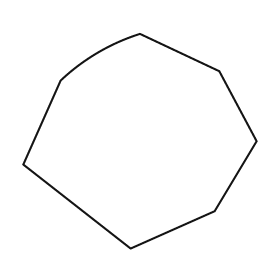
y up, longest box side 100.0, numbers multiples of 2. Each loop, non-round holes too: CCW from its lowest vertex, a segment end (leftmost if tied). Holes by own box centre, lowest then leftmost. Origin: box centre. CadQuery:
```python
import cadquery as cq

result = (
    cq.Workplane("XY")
    .moveTo(-4.0, -46.0)
    .lineTo(32.0, -30.0)
    .lineTo(50.0, 0.0)
    .lineTo(34.0, 30.0)
    .lineTo(0.0, 46.0)
    .threePointArc((-18.0, 38.0), (-34.0, 26.0))
    .lineTo(-50.0, -10.0)
    .close()
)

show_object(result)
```